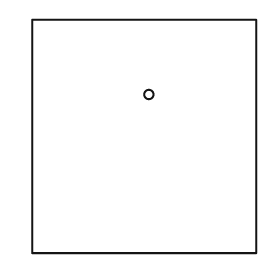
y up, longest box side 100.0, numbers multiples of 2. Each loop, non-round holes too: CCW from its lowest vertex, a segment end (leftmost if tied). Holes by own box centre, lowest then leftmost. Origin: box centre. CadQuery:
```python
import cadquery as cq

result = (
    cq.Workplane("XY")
    .moveTo(-48.0, -50.0)
    .lineTo(48.0, -50.0)
    .lineTo(48.0, 50.0)
    .lineTo(-48.0, 50.0)
    .close()
    .moveTo(2.0, 18.0)
    .circle(2.0)
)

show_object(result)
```